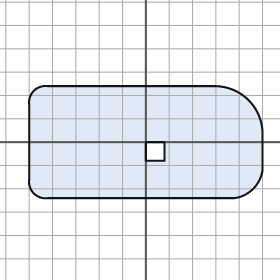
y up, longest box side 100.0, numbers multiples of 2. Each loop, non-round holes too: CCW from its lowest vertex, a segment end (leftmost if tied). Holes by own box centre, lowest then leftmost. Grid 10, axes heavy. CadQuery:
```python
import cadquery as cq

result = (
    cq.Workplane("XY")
    .moveTo(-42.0, -24.0)
    .lineTo(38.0, -24.0)
    .threePointArc((46.0, -20.0), (50.0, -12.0))
    .lineTo(50.0, 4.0)
    .threePointArc((44.0, 18.0), (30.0, 24.0))
    .lineTo(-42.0, 24.0)
    .threePointArc((-48.0, 22.0), (-50.0, 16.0))
    .lineTo(-50.0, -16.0)
    .threePointArc((-48.0, -22.0), (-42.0, -24.0))
    .close()
    .moveTo(0.0, -8.0)
    .lineTo(8.0, -8.0)
    .lineTo(8.0, 0.0)
    .lineTo(0.0, 0.0)
    .close()
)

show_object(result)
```